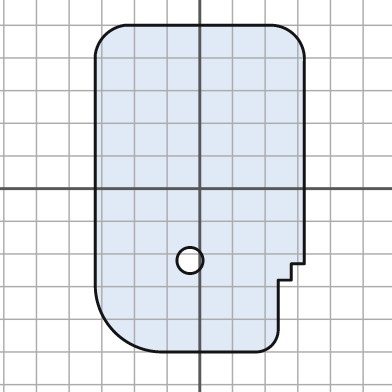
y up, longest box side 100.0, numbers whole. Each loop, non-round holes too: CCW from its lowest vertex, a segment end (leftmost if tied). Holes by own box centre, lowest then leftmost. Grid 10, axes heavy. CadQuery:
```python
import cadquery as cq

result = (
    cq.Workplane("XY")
    .moveTo(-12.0, -50.0)
    .lineTo(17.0, -50.0)
    .threePointArc((22.0, -48.0), (24.0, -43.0))
    .lineTo(24.0, -28.0)
    .lineTo(28.0, -28.0)
    .lineTo(28.0, -23.0)
    .lineTo(32.0, -23.0)
    .lineTo(32.0, 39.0)
    .threePointArc((29.0, 47.0), (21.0, 50.0))
    .lineTo(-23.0, 50.0)
    .threePointArc((-29.0, 47.0), (-32.0, 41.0))
    .lineTo(-32.0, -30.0)
    .threePointArc((-26.0, -44.0), (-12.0, -50.0))
    .close()
    .moveTo(-3.0, -22.0)
    .circle(4.0)
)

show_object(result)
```